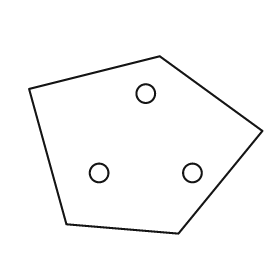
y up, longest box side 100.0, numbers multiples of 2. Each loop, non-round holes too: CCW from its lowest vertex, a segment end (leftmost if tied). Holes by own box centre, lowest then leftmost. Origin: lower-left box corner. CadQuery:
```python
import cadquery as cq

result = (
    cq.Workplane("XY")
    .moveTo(64.0, 0.0)
    .lineTo(100.0, 44.0)
    .lineTo(56.0, 76.0)
    .lineTo(0.0, 62.0)
    .lineTo(16.0, 4.0)
    .close()
    .moveTo(30.0, 26.0)
    .circle(4.0)
    .moveTo(70.0, 26.0)
    .circle(4.0)
    .moveTo(50.0, 60.0)
    .circle(4.0)
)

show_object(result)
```